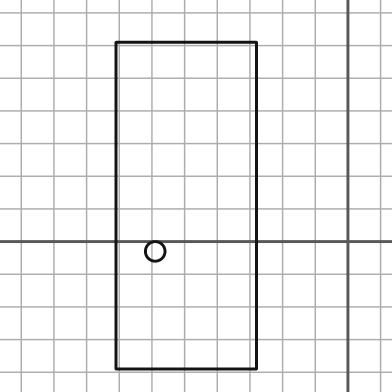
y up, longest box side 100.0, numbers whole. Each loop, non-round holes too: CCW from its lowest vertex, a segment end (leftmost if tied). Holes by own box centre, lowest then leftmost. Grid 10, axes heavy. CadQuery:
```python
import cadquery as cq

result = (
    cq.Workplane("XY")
    .moveTo(-71.0, -39.0)
    .lineTo(-28.0, -39.0)
    .lineTo(-28.0, 61.0)
    .lineTo(-71.0, 61.0)
    .close()
    .moveTo(-59.0, -3.0)
    .circle(3.0)
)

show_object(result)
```